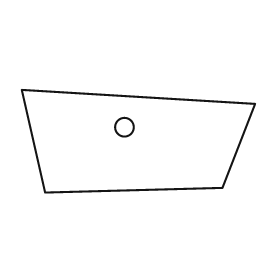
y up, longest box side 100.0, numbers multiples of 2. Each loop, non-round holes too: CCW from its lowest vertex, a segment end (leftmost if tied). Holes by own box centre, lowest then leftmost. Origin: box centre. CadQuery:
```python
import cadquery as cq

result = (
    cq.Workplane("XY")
    .moveTo(-40.0, -22.0)
    .lineTo(36.0, -20.0)
    .lineTo(50.0, 16.0)
    .lineTo(-50.0, 22.0)
    .close()
    .moveTo(-6.0, 6.0)
    .circle(4.0)
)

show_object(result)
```